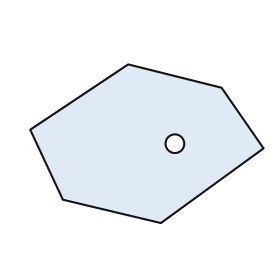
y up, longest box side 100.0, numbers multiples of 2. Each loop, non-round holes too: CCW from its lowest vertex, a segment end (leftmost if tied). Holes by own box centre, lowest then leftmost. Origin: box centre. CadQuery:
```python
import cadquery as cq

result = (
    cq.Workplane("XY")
    .moveTo(6.0, -34.0)
    .lineTo(50.0, -2.0)
    .lineTo(32.0, 24.0)
    .lineTo(-8.0, 34.0)
    .lineTo(-50.0, 6.0)
    .lineTo(-36.0, -24.0)
    .close()
    .moveTo(12.0, 0.0)
    .circle(4.0)
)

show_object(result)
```